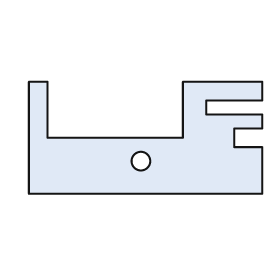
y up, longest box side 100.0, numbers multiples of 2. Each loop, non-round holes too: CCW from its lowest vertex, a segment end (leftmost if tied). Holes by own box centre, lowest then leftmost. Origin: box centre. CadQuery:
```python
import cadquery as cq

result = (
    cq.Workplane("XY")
    .moveTo(-50.0, -24.0)
    .lineTo(50.0, -24.0)
    .lineTo(50.0, -4.0)
    .lineTo(38.0, -4.0)
    .lineTo(38.0, 4.0)
    .lineTo(50.0, 4.0)
    .lineTo(50.0, 10.0)
    .lineTo(26.0, 10.0)
    .lineTo(26.0, 16.0)
    .lineTo(50.0, 16.0)
    .lineTo(50.0, 24.0)
    .lineTo(16.0, 24.0)
    .lineTo(16.0, 0.0)
    .lineTo(-42.0, 0.0)
    .lineTo(-42.0, 24.0)
    .lineTo(-50.0, 24.0)
    .close()
    .moveTo(-2.0, -10.0)
    .circle(4.0)
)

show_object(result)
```